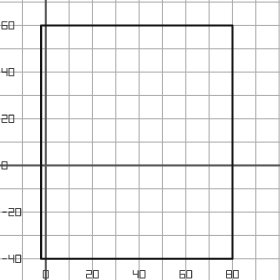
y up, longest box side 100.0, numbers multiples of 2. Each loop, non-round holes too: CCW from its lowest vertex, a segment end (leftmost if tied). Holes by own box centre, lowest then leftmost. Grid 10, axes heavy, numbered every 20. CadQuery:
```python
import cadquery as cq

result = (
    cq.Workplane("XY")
    .moveTo(-2.0, -40.0)
    .lineTo(80.0, -40.0)
    .lineTo(80.0, 60.0)
    .lineTo(-2.0, 60.0)
    .close()
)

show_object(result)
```